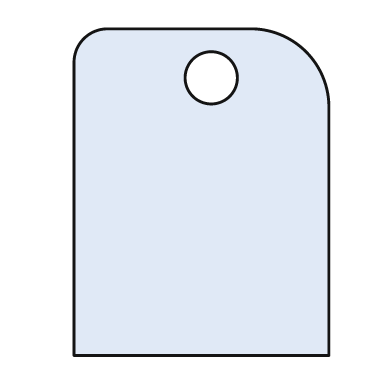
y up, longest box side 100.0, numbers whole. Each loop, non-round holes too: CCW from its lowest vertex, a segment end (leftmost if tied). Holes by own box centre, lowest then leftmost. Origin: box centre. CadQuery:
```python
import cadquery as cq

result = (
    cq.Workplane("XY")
    .moveTo(-39.0, -50.0)
    .lineTo(39.0, -50.0)
    .lineTo(39.0, 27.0)
    .threePointArc((32.0, 43.0), (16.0, 50.0))
    .lineTo(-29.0, 50.0)
    .threePointArc((-36.0, 47.0), (-39.0, 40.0))
    .close()
    .moveTo(3.0, 35.0)
    .circle(8.0)
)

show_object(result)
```